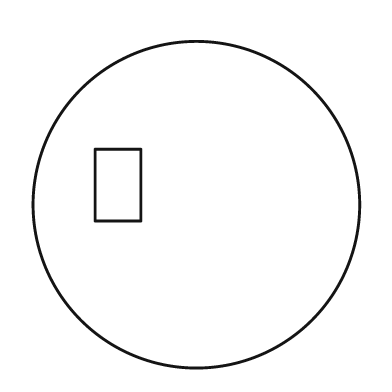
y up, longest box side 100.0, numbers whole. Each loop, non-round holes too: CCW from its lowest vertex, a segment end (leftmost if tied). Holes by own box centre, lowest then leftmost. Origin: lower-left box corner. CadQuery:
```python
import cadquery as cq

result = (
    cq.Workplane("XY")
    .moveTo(50.0, 50.0)
    .circle(50.0)
    .moveTo(19.0, 45.0)
    .lineTo(33.0, 45.0)
    .lineTo(33.0, 67.0)
    .lineTo(19.0, 67.0)
    .close()
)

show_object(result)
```